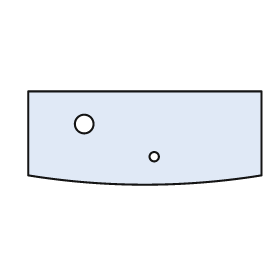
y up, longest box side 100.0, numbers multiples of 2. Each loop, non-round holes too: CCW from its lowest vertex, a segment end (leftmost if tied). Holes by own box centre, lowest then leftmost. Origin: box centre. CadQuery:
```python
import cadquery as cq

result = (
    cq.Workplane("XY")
    .moveTo(-50.0, -16.0)
    .threePointArc((0.0, -20.0), (50.0, -16.0))
    .lineTo(50.0, 20.0)
    .lineTo(-50.0, 20.0)
    .close()
    .moveTo(4.0, -8.0)
    .circle(2.0)
    .moveTo(-26.0, 6.0)
    .circle(4.0)
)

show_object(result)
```